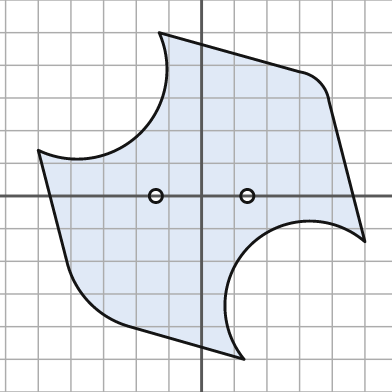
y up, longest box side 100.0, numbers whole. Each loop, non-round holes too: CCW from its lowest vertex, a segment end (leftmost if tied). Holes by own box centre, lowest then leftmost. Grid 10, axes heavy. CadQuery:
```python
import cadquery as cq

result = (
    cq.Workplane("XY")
    .moveTo(13.0, -50.0)
    .threePointArc((15.0, -15.0), (50.0, -14.0))
    .lineTo(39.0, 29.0)
    .threePointArc((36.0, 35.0), (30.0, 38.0))
    .lineTo(-13.0, 50.0)
    .threePointArc((-19.0, 19.0), (-50.0, 14.0))
    .lineTo(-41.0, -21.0)
    .threePointArc((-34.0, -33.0), (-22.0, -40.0))
    .close()
    .moveTo(-14.0, 0.0)
    .circle(2.0)
    .moveTo(14.0, 0.0)
    .circle(2.0)
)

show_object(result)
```